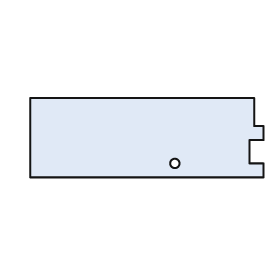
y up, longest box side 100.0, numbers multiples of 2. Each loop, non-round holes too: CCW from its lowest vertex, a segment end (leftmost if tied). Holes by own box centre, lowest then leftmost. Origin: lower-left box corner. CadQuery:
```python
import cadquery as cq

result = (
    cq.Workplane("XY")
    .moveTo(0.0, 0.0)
    .lineTo(100.0, 0.0)
    .lineTo(100.0, 6.0)
    .lineTo(94.0, 6.0)
    .lineTo(94.0, 16.0)
    .lineTo(100.0, 16.0)
    .lineTo(100.0, 22.0)
    .lineTo(96.0, 22.0)
    .lineTo(96.0, 34.0)
    .lineTo(0.0, 34.0)
    .close()
    .moveTo(62.0, 6.0)
    .circle(2.0)
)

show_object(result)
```